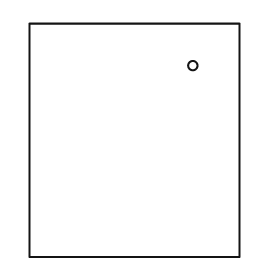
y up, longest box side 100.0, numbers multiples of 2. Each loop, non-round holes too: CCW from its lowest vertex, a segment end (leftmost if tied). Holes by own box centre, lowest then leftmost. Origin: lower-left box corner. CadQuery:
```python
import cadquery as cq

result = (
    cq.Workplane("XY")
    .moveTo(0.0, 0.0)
    .lineTo(90.0, 0.0)
    .lineTo(90.0, 100.0)
    .lineTo(0.0, 100.0)
    .close()
    .moveTo(70.0, 82.0)
    .circle(2.0)
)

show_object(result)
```